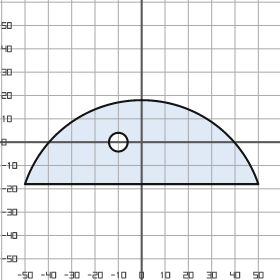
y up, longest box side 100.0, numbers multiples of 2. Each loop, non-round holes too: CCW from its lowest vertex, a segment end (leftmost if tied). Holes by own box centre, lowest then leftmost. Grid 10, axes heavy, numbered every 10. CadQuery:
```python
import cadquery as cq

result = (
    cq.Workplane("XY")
    .moveTo(-50.0, -18.0)
    .lineTo(50.0, -18.0)
    .threePointArc((0.0, 18.0), (-50.0, -18.0))
    .close()
    .moveTo(-10.0, 0.0)
    .circle(4.0)
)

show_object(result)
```